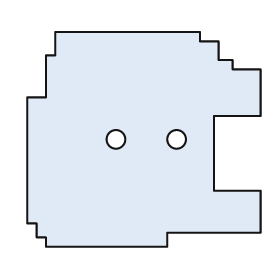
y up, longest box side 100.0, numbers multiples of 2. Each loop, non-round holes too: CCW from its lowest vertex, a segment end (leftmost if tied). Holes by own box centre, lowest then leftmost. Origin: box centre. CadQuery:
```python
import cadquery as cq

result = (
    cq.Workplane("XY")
    .moveTo(-42.0, -46.0)
    .lineTo(10.0, -46.0)
    .lineTo(10.0, -40.0)
    .lineTo(50.0, -40.0)
    .lineTo(50.0, -22.0)
    .lineTo(30.0, -22.0)
    .lineTo(30.0, 10.0)
    .lineTo(50.0, 10.0)
    .lineTo(50.0, 30.0)
    .lineTo(38.0, 30.0)
    .lineTo(38.0, 34.0)
    .lineTo(32.0, 34.0)
    .lineTo(32.0, 42.0)
    .lineTo(24.0, 42.0)
    .lineTo(24.0, 46.0)
    .lineTo(-38.0, 46.0)
    .lineTo(-38.0, 36.0)
    .lineTo(-42.0, 36.0)
    .lineTo(-42.0, 18.0)
    .lineTo(-50.0, 18.0)
    .lineTo(-50.0, -36.0)
    .lineTo(-46.0, -36.0)
    .lineTo(-46.0, -42.0)
    .lineTo(-42.0, -42.0)
    .close()
    .moveTo(-12.0, 0.0)
    .circle(4.0)
    .moveTo(14.0, 0.0)
    .circle(4.0)
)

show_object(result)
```